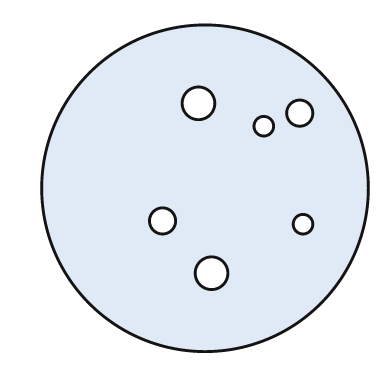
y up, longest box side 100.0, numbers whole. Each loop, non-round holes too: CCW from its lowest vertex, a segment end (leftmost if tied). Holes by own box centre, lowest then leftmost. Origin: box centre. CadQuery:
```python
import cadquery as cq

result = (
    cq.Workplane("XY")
    .moveTo(0.0, 0.0)
    .circle(50.0)
    .moveTo(2.0, -26.0)
    .circle(5.0)
    .moveTo(30.0, -11.0)
    .circle(3.0)
    .moveTo(-13.0, -10.0)
    .circle(4.0)
    .moveTo(18.0, 19.0)
    .circle(3.0)
    .moveTo(29.0, 23.0)
    .circle(4.0)
    .moveTo(-2.0, 26.0)
    .circle(5.0)
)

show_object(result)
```